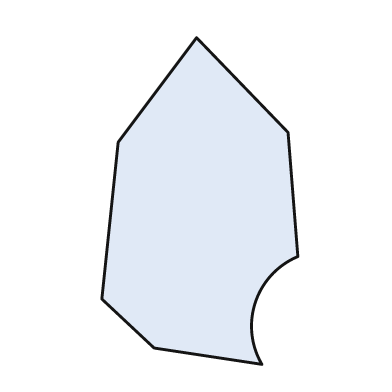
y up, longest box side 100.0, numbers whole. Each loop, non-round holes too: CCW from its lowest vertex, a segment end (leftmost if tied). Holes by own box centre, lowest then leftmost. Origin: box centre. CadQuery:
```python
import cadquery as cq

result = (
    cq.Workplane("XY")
    .moveTo(19.0, -50.0)
    .threePointArc((17.0, -31.0), (30.0, -17.0))
    .lineTo(27.0, 21.0)
    .lineTo(-1.0, 50.0)
    .lineTo(-25.0, 18.0)
    .lineTo(-30.0, -30.0)
    .lineTo(-14.0, -45.0)
    .close()
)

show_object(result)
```